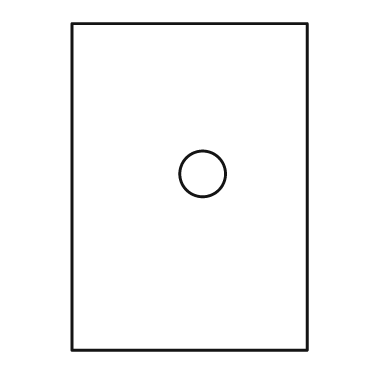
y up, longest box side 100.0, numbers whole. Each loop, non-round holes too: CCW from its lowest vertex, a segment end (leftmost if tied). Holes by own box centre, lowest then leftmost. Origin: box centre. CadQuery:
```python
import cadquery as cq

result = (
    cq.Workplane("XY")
    .moveTo(-36.0, -50.0)
    .lineTo(36.0, -50.0)
    .lineTo(36.0, 50.0)
    .lineTo(-36.0, 50.0)
    .close()
    .moveTo(4.0, 4.0)
    .circle(7.0)
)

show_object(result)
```